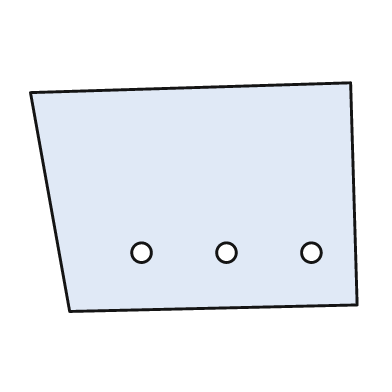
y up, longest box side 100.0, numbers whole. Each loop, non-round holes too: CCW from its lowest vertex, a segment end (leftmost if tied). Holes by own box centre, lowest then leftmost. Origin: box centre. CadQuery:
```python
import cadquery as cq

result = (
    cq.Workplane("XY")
    .moveTo(-38.0, -35.0)
    .lineTo(50.0, -33.0)
    .lineTo(48.0, 35.0)
    .lineTo(-50.0, 32.0)
    .close()
    .moveTo(-16.0, -17.0)
    .circle(3.0)
    .moveTo(10.0, -17.0)
    .circle(3.0)
    .moveTo(36.0, -17.0)
    .circle(3.0)
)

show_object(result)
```